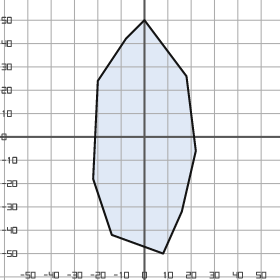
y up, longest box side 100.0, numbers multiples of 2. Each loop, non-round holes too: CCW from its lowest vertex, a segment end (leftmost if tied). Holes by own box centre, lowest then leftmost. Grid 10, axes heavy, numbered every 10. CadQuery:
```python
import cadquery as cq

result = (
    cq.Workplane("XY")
    .moveTo(8.0, -50.0)
    .lineTo(16.0, -32.0)
    .lineTo(22.0, -6.0)
    .lineTo(18.0, 26.0)
    .lineTo(0.0, 50.0)
    .lineTo(-8.0, 42.0)
    .lineTo(-20.0, 24.0)
    .lineTo(-22.0, -18.0)
    .lineTo(-14.0, -42.0)
    .close()
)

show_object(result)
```